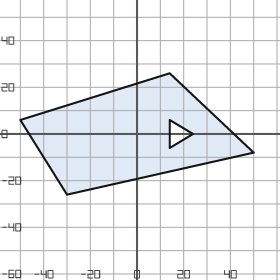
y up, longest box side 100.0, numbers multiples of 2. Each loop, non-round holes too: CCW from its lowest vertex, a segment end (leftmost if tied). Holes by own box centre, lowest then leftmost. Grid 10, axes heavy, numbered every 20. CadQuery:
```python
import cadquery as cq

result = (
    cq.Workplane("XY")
    .moveTo(-30.0, -26.0)
    .lineTo(50.0, -8.0)
    .lineTo(14.0, 26.0)
    .lineTo(-50.0, 6.0)
    .close()
    .moveTo(14.0, -6.0)
    .lineTo(24.0, 0.0)
    .lineTo(14.0, 6.0)
    .close()
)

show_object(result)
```